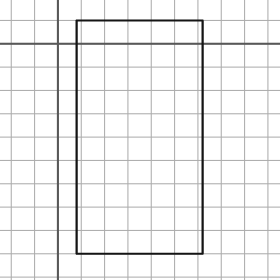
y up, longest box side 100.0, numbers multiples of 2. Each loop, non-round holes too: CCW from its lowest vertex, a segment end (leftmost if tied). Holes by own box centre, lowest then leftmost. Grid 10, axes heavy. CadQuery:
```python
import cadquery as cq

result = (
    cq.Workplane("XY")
    .moveTo(8.0, -90.0)
    .lineTo(62.0, -90.0)
    .lineTo(62.0, 10.0)
    .lineTo(8.0, 10.0)
    .close()
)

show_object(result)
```